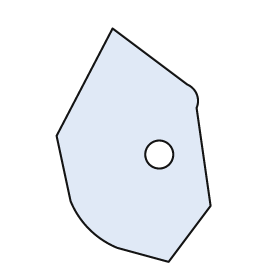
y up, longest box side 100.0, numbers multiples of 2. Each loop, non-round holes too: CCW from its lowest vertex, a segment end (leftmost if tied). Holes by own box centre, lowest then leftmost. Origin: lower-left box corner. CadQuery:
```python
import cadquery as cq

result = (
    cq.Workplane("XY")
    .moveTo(48.0, 0.0)
    .lineTo(66.0, 24.0)
    .lineTo(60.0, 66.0)
    .threePointArc((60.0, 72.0), (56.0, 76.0))
    .lineTo(24.0, 100.0)
    .lineTo(0.0, 54.0)
    .lineTo(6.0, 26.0)
    .threePointArc((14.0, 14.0), (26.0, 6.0))
    .close()
    .moveTo(44.0, 46.0)
    .circle(6.0)
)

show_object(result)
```